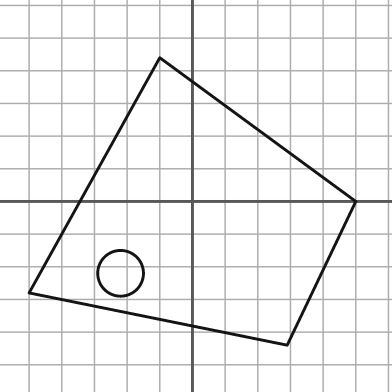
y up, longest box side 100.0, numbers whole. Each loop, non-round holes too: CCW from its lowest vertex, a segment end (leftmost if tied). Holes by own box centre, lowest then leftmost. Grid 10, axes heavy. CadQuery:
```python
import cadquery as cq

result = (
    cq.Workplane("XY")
    .moveTo(29.0, -44.0)
    .lineTo(50.0, 0.0)
    .lineTo(-10.0, 44.0)
    .lineTo(-50.0, -28.0)
    .close()
    .moveTo(-22.0, -22.0)
    .circle(7.0)
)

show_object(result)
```